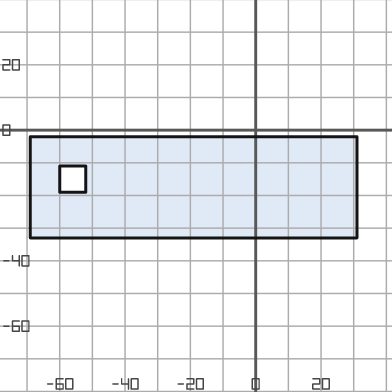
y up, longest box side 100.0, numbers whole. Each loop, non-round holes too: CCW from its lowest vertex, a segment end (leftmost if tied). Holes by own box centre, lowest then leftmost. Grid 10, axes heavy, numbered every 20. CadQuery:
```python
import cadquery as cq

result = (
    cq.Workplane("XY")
    .moveTo(-69.0, -33.0)
    .lineTo(31.0, -33.0)
    .lineTo(31.0, -2.0)
    .lineTo(-69.0, -2.0)
    .close()
    .moveTo(-60.0, -19.0)
    .lineTo(-52.0, -19.0)
    .lineTo(-52.0, -11.0)
    .lineTo(-60.0, -11.0)
    .close()
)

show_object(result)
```